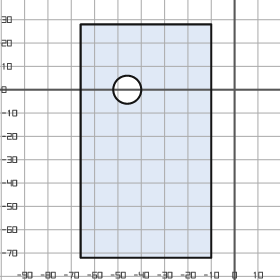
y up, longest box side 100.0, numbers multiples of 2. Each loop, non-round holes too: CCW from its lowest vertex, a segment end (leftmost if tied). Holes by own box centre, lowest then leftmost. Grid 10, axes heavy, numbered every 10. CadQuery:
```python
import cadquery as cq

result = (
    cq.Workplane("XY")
    .moveTo(-66.0, -72.0)
    .lineTo(-10.0, -72.0)
    .lineTo(-10.0, 28.0)
    .lineTo(-66.0, 28.0)
    .close()
    .moveTo(-46.0, 0.0)
    .circle(6.0)
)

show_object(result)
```